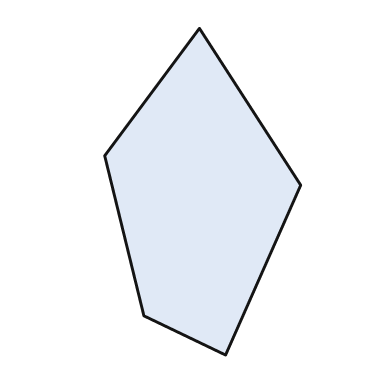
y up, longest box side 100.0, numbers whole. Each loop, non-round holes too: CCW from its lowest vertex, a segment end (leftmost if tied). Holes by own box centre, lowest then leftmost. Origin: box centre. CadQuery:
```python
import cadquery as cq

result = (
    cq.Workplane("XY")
    .moveTo(7.0, -50.0)
    .lineTo(30.0, 2.0)
    .lineTo(-1.0, 50.0)
    .lineTo(-30.0, 11.0)
    .lineTo(-18.0, -38.0)
    .close()
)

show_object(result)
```